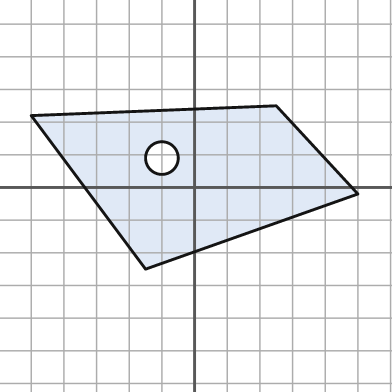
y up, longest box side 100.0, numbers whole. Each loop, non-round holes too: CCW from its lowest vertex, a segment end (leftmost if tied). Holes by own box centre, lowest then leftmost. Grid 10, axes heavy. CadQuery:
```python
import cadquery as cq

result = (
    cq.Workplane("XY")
    .moveTo(-15.0, -25.0)
    .lineTo(50.0, -2.0)
    .lineTo(25.0, 25.0)
    .lineTo(-50.0, 22.0)
    .close()
    .moveTo(-10.0, 9.0)
    .circle(5.0)
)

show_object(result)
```